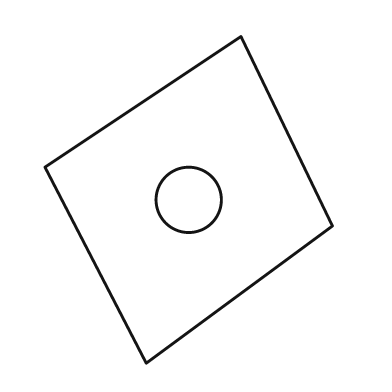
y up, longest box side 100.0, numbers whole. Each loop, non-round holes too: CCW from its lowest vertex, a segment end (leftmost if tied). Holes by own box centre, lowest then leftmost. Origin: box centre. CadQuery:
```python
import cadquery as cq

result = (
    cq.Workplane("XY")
    .moveTo(-13.0, -50.0)
    .lineTo(44.0, -8.0)
    .lineTo(16.0, 50.0)
    .lineTo(-44.0, 10.0)
    .close()
    .moveTo(0.0, 0.0)
    .circle(10.0)
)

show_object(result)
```